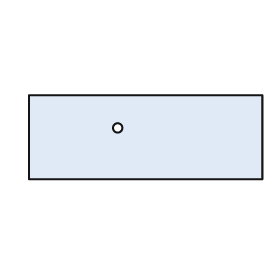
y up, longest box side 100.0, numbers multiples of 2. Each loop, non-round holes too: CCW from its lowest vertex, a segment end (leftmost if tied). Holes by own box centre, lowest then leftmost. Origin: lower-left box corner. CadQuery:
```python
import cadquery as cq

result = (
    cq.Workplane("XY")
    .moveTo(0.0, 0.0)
    .lineTo(100.0, 0.0)
    .lineTo(100.0, 36.0)
    .lineTo(0.0, 36.0)
    .close()
    .moveTo(38.0, 22.0)
    .circle(2.0)
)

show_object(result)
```